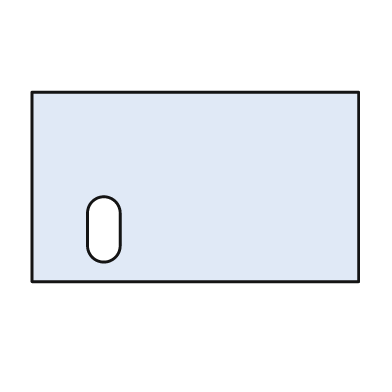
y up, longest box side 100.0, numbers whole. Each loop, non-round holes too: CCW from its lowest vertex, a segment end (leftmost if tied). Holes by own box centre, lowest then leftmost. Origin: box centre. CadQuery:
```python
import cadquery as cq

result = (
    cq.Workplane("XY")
    .moveTo(-50.0, -29.0)
    .lineTo(50.0, -29.0)
    .lineTo(50.0, 29.0)
    .lineTo(-50.0, 29.0)
    .close()
    .moveTo(-33.0, -18.0)
    .threePointArc((-28.0, -23.0), (-23.0, -18.0))
    .lineTo(-23.0, -8.0)
    .threePointArc((-28.0, -3.0), (-33.0, -8.0))
    .close()
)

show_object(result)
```